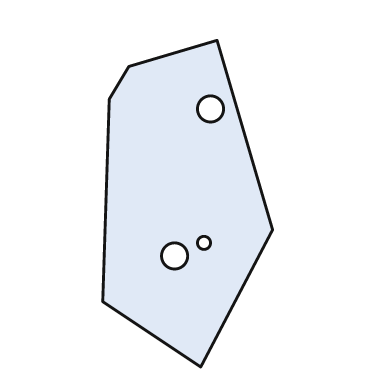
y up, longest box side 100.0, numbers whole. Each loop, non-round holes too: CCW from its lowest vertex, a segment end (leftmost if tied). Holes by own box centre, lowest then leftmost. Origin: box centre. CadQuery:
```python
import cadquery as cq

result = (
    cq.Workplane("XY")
    .moveTo(4.0, -50.0)
    .lineTo(26.0, -8.0)
    .lineTo(9.0, 50.0)
    .lineTo(-18.0, 42.0)
    .lineTo(-24.0, 32.0)
    .lineTo(-26.0, -30.0)
    .close()
    .moveTo(-4.0, -16.0)
    .circle(4.0)
    .moveTo(5.0, -12.0)
    .circle(2.0)
    .moveTo(7.0, 29.0)
    .circle(4.0)
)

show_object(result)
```